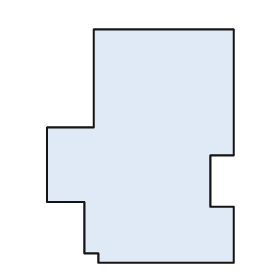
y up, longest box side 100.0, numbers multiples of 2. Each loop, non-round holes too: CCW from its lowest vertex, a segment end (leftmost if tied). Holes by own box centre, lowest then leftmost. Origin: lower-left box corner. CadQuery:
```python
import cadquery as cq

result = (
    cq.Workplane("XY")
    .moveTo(22.0, 0.0)
    .lineTo(80.0, 0.0)
    .lineTo(80.0, 24.0)
    .lineTo(70.0, 24.0)
    .lineTo(70.0, 46.0)
    .lineTo(80.0, 46.0)
    .lineTo(80.0, 100.0)
    .lineTo(20.0, 100.0)
    .lineTo(20.0, 58.0)
    .lineTo(0.0, 58.0)
    .lineTo(0.0, 26.0)
    .lineTo(16.0, 26.0)
    .lineTo(16.0, 4.0)
    .lineTo(22.0, 4.0)
    .close()
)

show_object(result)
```